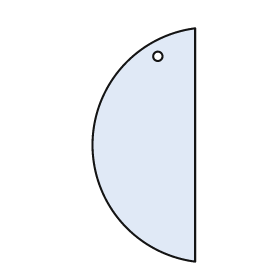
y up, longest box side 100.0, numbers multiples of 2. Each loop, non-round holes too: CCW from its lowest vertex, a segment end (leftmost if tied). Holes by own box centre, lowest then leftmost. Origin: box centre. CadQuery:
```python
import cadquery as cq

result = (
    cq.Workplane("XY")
    .moveTo(22.0, -50.0)
    .lineTo(22.0, 50.0)
    .threePointArc((-22.0, 0.0), (22.0, -50.0))
    .close()
    .moveTo(6.0, 38.0)
    .circle(2.0)
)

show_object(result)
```